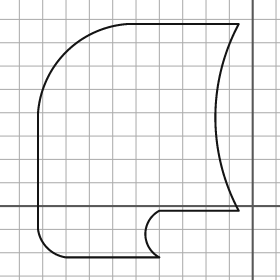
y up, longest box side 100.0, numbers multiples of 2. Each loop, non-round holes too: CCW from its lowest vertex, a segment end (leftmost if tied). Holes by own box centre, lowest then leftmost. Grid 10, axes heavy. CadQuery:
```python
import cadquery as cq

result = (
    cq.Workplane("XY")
    .moveTo(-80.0, -22.0)
    .lineTo(-40.0, -22.0)
    .threePointArc((-46.0, -12.0), (-40.0, -2.0))
    .lineTo(-6.0, -2.0)
    .threePointArc((-16.0, 38.0), (-6.0, 78.0))
    .lineTo(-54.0, 78.0)
    .threePointArc((-80.0, 66.0), (-92.0, 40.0))
    .lineTo(-92.0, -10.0)
    .threePointArc((-88.0, -18.0), (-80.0, -22.0))
    .close()
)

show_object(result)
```